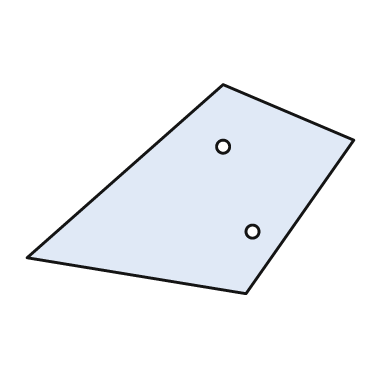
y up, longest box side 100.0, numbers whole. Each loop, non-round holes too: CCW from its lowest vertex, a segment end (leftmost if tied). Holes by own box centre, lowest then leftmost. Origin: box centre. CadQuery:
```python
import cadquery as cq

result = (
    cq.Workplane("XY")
    .moveTo(17.0, -32.0)
    .lineTo(50.0, 15.0)
    .lineTo(10.0, 32.0)
    .lineTo(-50.0, -21.0)
    .close()
    .moveTo(19.0, -13.0)
    .circle(2.0)
    .moveTo(10.0, 13.0)
    .circle(2.0)
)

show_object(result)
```